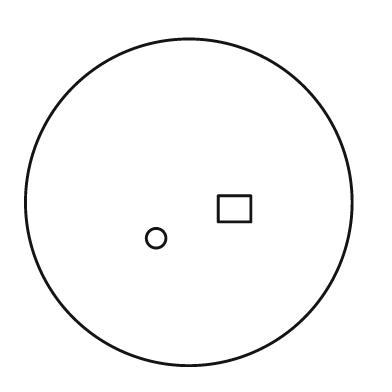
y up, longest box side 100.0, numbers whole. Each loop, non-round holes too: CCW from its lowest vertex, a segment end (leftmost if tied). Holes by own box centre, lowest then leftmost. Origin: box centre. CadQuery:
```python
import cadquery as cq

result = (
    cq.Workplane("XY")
    .moveTo(0.0, 0.0)
    .circle(50.0)
    .moveTo(-10.0, -11.0)
    .circle(3.0)
    .moveTo(9.0, -6.0)
    .lineTo(19.0, -6.0)
    .lineTo(19.0, 2.0)
    .lineTo(9.0, 2.0)
    .close()
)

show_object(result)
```